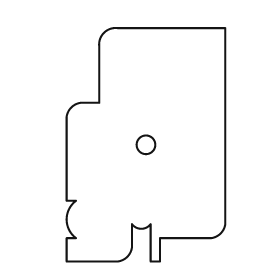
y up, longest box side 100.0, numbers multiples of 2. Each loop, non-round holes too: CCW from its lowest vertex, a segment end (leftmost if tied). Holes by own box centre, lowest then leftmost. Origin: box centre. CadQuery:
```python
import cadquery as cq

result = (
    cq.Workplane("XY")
    .moveTo(-34.0, -50.0)
    .lineTo(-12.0, -50.0)
    .threePointArc((-8.0, -48.0), (-6.0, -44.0))
    .lineTo(-6.0, -34.0)
    .threePointArc((-2.0, -36.0), (2.0, -34.0))
    .lineTo(2.0, -50.0)
    .lineTo(6.0, -50.0)
    .lineTo(6.0, -40.0)
    .lineTo(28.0, -40.0)
    .threePointArc((32.0, -38.0), (34.0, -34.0))
    .lineTo(34.0, 50.0)
    .lineTo(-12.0, 50.0)
    .threePointArc((-18.0, 48.0), (-20.0, 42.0))
    .lineTo(-20.0, 18.0)
    .lineTo(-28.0, 18.0)
    .threePointArc((-32.0, 16.0), (-34.0, 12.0))
    .lineTo(-34.0, -24.0)
    .lineTo(-30.0, -24.0)
    .threePointArc((-34.0, -32.0), (-30.0, -40.0))
    .lineTo(-34.0, -40.0)
    .close()
    .moveTo(0.0, 0.0)
    .circle(4.0)
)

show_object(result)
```